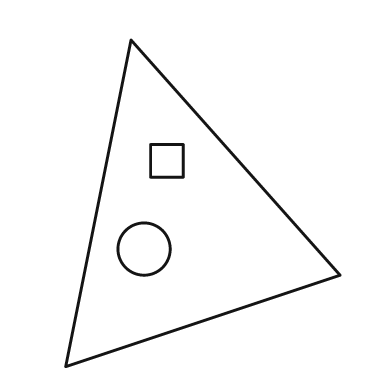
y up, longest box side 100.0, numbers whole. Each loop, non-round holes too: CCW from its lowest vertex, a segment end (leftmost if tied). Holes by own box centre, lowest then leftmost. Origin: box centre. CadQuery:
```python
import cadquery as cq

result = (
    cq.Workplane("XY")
    .moveTo(-42.0, -50.0)
    .lineTo(42.0, -22.0)
    .lineTo(-22.0, 50.0)
    .close()
    .moveTo(-18.0, -14.0)
    .circle(8.0)
    .moveTo(-16.0, 8.0)
    .lineTo(-6.0, 8.0)
    .lineTo(-6.0, 18.0)
    .lineTo(-16.0, 18.0)
    .close()
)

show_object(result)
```